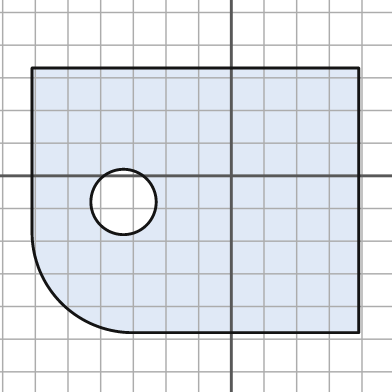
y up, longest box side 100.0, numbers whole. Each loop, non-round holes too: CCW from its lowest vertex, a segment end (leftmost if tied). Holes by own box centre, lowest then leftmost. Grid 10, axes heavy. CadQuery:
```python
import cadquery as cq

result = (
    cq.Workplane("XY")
    .moveTo(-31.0, -48.0)
    .lineTo(39.0, -48.0)
    .lineTo(39.0, 33.0)
    .lineTo(-61.0, 33.0)
    .lineTo(-61.0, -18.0)
    .threePointArc((-52.0, -39.0), (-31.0, -48.0))
    .close()
    .moveTo(-33.0, -8.0)
    .circle(10.0)
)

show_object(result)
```